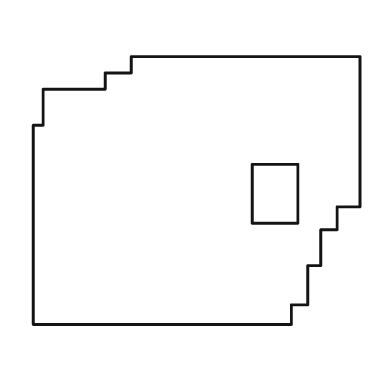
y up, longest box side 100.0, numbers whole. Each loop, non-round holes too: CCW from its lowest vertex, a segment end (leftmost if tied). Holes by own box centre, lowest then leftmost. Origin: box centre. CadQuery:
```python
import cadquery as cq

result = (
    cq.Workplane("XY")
    .moveTo(-50.0, -41.0)
    .lineTo(29.0, -41.0)
    .lineTo(29.0, -35.0)
    .lineTo(34.0, -35.0)
    .lineTo(34.0, -23.0)
    .lineTo(38.0, -23.0)
    .lineTo(38.0, -12.0)
    .lineTo(43.0, -12.0)
    .lineTo(43.0, -5.0)
    .lineTo(50.0, -5.0)
    .lineTo(50.0, 41.0)
    .lineTo(-20.0, 41.0)
    .lineTo(-20.0, 36.0)
    .lineTo(-28.0, 36.0)
    .lineTo(-28.0, 31.0)
    .lineTo(-47.0, 31.0)
    .lineTo(-47.0, 20.0)
    .lineTo(-50.0, 20.0)
    .close()
    .moveTo(17.0, -10.0)
    .lineTo(31.0, -10.0)
    .lineTo(31.0, 8.0)
    .lineTo(17.0, 8.0)
    .close()
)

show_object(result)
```